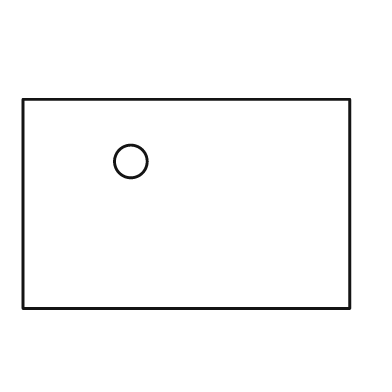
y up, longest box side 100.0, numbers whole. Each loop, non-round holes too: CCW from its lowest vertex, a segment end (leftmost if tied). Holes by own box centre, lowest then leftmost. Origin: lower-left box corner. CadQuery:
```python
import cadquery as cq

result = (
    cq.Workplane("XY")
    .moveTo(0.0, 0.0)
    .lineTo(100.0, 0.0)
    .lineTo(100.0, 64.0)
    .lineTo(0.0, 64.0)
    .close()
    .moveTo(33.0, 45.0)
    .circle(5.0)
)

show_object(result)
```